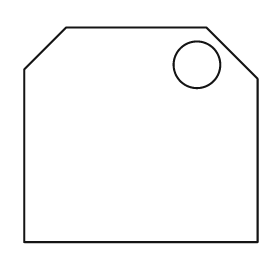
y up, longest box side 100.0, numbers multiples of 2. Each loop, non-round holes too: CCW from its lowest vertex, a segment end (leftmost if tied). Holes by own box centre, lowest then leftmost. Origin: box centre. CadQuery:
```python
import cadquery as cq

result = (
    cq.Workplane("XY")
    .moveTo(-50.0, -46.0)
    .lineTo(50.0, -46.0)
    .lineTo(50.0, 24.0)
    .lineTo(28.0, 46.0)
    .lineTo(-32.0, 46.0)
    .lineTo(-50.0, 28.0)
    .close()
    .moveTo(24.0, 30.0)
    .circle(10.0)
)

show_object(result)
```